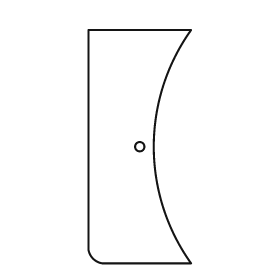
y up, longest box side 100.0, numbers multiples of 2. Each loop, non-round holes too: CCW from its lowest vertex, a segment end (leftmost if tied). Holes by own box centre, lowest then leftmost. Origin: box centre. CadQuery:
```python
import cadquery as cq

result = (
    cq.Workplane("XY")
    .moveTo(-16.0, -50.0)
    .lineTo(22.0, -50.0)
    .threePointArc((6.0, 0.0), (22.0, 50.0))
    .lineTo(-22.0, 50.0)
    .lineTo(-22.0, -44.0)
    .threePointArc((-20.0, -48.0), (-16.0, -50.0))
    .close()
    .moveTo(0.0, 0.0)
    .circle(2.0)
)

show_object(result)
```